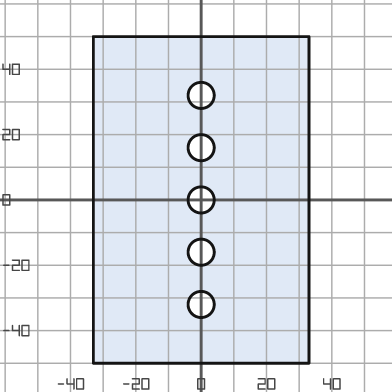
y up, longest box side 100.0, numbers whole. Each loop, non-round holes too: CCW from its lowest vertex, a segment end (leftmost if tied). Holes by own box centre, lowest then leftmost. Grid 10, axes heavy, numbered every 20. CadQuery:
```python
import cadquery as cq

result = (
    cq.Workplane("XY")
    .moveTo(-33.0, -50.0)
    .lineTo(33.0, -50.0)
    .lineTo(33.0, 50.0)
    .lineTo(-33.0, 50.0)
    .close()
    .moveTo(0.0, -32.0)
    .circle(4.0)
    .moveTo(0.0, -16.0)
    .circle(4.0)
    .moveTo(0.0, 0.0)
    .circle(4.0)
    .moveTo(0.0, 16.0)
    .circle(4.0)
    .moveTo(0.0, 32.0)
    .circle(4.0)
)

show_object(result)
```